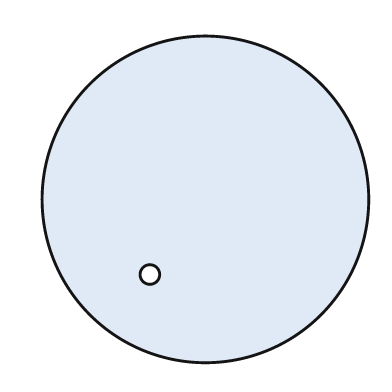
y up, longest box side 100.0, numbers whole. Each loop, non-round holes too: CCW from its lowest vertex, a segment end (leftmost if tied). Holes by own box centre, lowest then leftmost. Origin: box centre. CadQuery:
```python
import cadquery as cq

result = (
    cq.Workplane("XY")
    .moveTo(0.0, 0.0)
    .circle(50.0)
    .moveTo(-17.0, -23.0)
    .circle(3.0)
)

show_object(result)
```